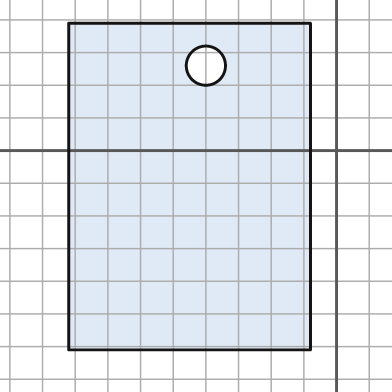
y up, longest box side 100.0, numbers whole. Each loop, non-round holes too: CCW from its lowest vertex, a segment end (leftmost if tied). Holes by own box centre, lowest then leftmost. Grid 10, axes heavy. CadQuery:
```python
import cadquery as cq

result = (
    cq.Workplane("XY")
    .moveTo(-82.0, -61.0)
    .lineTo(-8.0, -61.0)
    .lineTo(-8.0, 39.0)
    .lineTo(-82.0, 39.0)
    .close()
    .moveTo(-40.0, 26.0)
    .circle(6.0)
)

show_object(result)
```